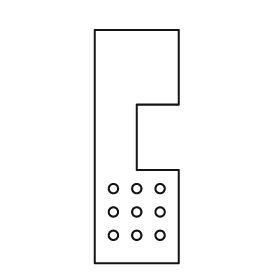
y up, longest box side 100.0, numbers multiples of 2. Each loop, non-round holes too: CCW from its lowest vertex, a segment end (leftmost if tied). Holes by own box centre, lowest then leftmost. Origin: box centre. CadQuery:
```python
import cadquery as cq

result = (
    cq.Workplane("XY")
    .moveTo(-18.0, -50.0)
    .lineTo(18.0, -50.0)
    .lineTo(18.0, -10.0)
    .lineTo(0.0, -10.0)
    .lineTo(0.0, 18.0)
    .lineTo(18.0, 18.0)
    .lineTo(18.0, 50.0)
    .lineTo(-18.0, 50.0)
    .close()
    .moveTo(-10.0, -38.0)
    .circle(2.0)
    .moveTo(0.0, -38.0)
    .circle(2.0)
    .moveTo(10.0, -38.0)
    .circle(2.0)
    .moveTo(-10.0, -28.0)
    .circle(2.0)
    .moveTo(0.0, -28.0)
    .circle(2.0)
    .moveTo(10.0, -28.0)
    .circle(2.0)
    .moveTo(-10.0, -18.0)
    .circle(2.0)
    .moveTo(0.0, -18.0)
    .circle(2.0)
    .moveTo(10.0, -18.0)
    .circle(2.0)
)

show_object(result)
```